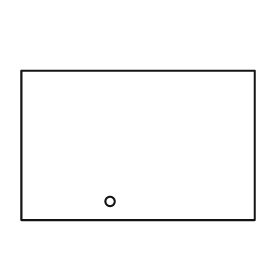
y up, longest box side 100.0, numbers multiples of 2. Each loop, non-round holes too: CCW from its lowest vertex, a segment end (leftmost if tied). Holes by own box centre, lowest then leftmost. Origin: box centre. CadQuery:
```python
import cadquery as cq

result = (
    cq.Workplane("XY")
    .moveTo(-50.0, -32.0)
    .lineTo(50.0, -32.0)
    .lineTo(50.0, 32.0)
    .lineTo(-50.0, 32.0)
    .close()
    .moveTo(-12.0, -24.0)
    .circle(2.0)
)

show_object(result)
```